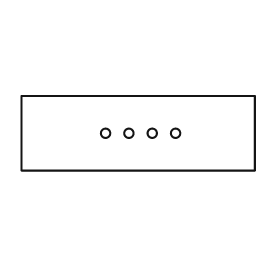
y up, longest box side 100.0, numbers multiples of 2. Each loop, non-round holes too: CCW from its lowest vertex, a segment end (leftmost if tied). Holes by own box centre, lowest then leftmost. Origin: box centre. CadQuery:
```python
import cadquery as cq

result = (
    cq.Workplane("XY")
    .moveTo(-50.0, -16.0)
    .lineTo(50.0, -16.0)
    .lineTo(50.0, 16.0)
    .lineTo(-50.0, 16.0)
    .close()
    .moveTo(-14.0, 0.0)
    .circle(2.0)
    .moveTo(-4.0, 0.0)
    .circle(2.0)
    .moveTo(6.0, 0.0)
    .circle(2.0)
    .moveTo(16.0, 0.0)
    .circle(2.0)
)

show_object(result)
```